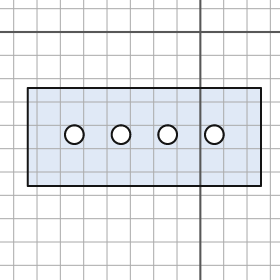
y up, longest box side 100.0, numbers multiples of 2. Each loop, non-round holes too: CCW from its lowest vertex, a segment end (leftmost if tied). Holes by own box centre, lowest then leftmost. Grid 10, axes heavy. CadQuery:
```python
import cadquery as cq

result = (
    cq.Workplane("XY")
    .moveTo(-74.0, -66.0)
    .lineTo(26.0, -66.0)
    .lineTo(26.0, -24.0)
    .lineTo(-74.0, -24.0)
    .close()
    .moveTo(-54.0, -44.0)
    .circle(4.0)
    .moveTo(-34.0, -44.0)
    .circle(4.0)
    .moveTo(-14.0, -44.0)
    .circle(4.0)
    .moveTo(6.0, -44.0)
    .circle(4.0)
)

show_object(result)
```